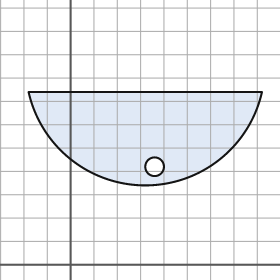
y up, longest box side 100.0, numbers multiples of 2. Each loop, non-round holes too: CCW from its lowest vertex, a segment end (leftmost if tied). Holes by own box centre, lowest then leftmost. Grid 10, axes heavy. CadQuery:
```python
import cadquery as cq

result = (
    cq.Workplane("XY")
    .moveTo(-18.0, 74.0)
    .threePointArc((32.0, 34.0), (82.0, 74.0))
    .close()
    .moveTo(36.0, 42.0)
    .circle(4.0)
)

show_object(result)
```